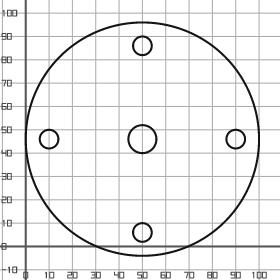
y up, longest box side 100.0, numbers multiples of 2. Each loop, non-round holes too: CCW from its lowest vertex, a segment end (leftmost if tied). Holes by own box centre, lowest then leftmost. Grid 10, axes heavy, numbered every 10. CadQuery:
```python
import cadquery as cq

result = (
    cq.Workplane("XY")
    .moveTo(50.0, 46.0)
    .circle(50.0)
    .moveTo(50.0, 6.0)
    .circle(4.0)
    .moveTo(10.0, 46.0)
    .circle(4.0)
    .moveTo(50.0, 46.0)
    .circle(6.0)
    .moveTo(90.0, 46.0)
    .circle(4.0)
    .moveTo(50.0, 86.0)
    .circle(4.0)
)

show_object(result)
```